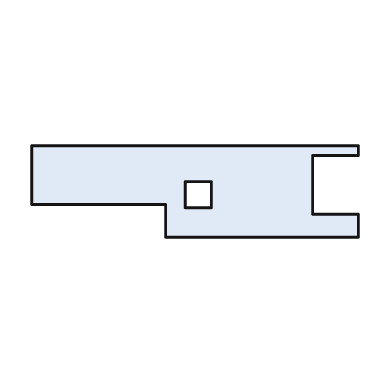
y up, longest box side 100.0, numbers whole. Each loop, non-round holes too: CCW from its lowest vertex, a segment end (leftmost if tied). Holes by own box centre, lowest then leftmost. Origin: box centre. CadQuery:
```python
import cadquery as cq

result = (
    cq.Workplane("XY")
    .moveTo(-9.0, -14.0)
    .lineTo(50.0, -14.0)
    .lineTo(50.0, -7.0)
    .lineTo(36.0, -7.0)
    .lineTo(36.0, 11.0)
    .lineTo(50.0, 11.0)
    .lineTo(50.0, 14.0)
    .lineTo(-50.0, 14.0)
    .lineTo(-50.0, -4.0)
    .lineTo(-9.0, -4.0)
    .close()
    .moveTo(-3.0, -5.0)
    .lineTo(5.0, -5.0)
    .lineTo(5.0, 3.0)
    .lineTo(-3.0, 3.0)
    .close()
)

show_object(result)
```